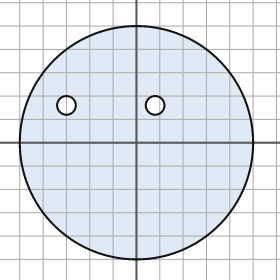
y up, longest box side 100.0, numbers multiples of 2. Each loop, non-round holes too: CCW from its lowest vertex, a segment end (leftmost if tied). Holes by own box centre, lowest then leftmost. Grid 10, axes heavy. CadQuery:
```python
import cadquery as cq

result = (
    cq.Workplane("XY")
    .moveTo(0.0, 0.0)
    .circle(50.0)
    .moveTo(-30.0, 16.0)
    .circle(4.0)
    .moveTo(8.0, 16.0)
    .circle(4.0)
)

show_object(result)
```